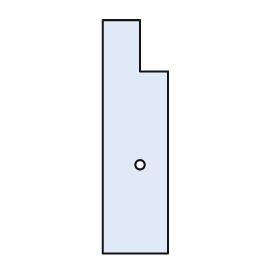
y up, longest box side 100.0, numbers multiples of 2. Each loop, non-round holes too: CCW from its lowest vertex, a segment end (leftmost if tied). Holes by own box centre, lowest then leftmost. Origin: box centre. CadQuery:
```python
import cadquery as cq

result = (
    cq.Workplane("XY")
    .moveTo(-14.0, -50.0)
    .lineTo(14.0, -50.0)
    .lineTo(14.0, 28.0)
    .lineTo(2.0, 28.0)
    .lineTo(2.0, 50.0)
    .lineTo(-14.0, 50.0)
    .close()
    .moveTo(2.0, -12.0)
    .circle(2.0)
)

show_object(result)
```